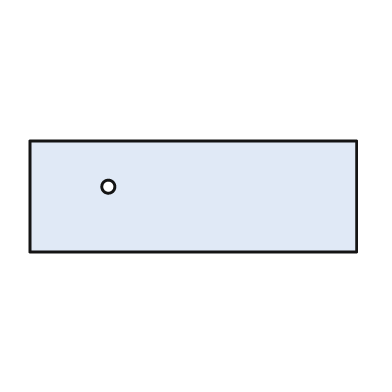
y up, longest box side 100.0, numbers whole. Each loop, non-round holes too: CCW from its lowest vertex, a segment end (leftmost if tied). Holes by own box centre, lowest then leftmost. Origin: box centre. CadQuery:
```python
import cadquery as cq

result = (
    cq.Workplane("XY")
    .moveTo(-50.0, -17.0)
    .lineTo(50.0, -17.0)
    .lineTo(50.0, 17.0)
    .lineTo(-50.0, 17.0)
    .close()
    .moveTo(-26.0, 3.0)
    .circle(2.0)
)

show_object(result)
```